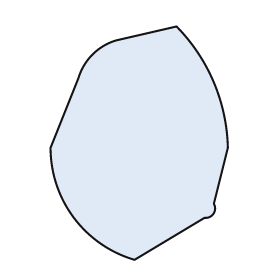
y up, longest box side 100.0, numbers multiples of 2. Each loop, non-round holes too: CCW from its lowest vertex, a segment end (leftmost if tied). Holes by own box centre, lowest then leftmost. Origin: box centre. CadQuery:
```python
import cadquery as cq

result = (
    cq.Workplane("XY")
    .moveTo(-2.0, -50.0)
    .lineTo(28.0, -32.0)
    .threePointArc((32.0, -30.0), (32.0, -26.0))
    .lineTo(38.0, -2.0)
    .threePointArc((32.0, 26.0), (16.0, 50.0))
    .lineTo(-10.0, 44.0)
    .threePointArc((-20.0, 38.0), (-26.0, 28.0))
    .lineTo(-38.0, -2.0)
    .threePointArc((-28.0, -32.0), (-2.0, -50.0))
    .close()
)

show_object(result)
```